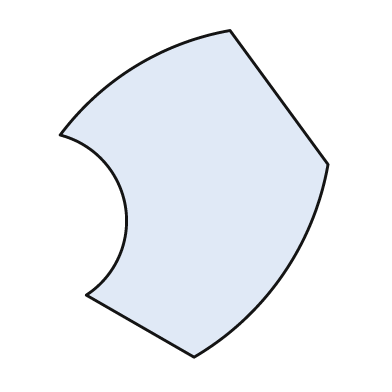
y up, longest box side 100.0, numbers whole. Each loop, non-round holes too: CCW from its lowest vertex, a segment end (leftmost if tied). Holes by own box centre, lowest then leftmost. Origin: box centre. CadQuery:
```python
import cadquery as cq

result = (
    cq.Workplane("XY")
    .moveTo(0.0, -50.0)
    .threePointArc((27.0, -25.0), (41.0, 9.0))
    .lineTo(11.0, 50.0)
    .threePointArc((-18.0, 39.0), (-41.0, 18.0))
    .threePointArc((-21.0, -4.0), (-33.0, -31.0))
    .close()
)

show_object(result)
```